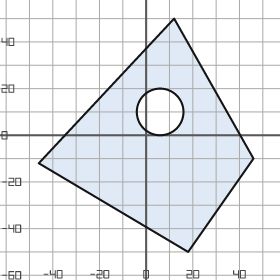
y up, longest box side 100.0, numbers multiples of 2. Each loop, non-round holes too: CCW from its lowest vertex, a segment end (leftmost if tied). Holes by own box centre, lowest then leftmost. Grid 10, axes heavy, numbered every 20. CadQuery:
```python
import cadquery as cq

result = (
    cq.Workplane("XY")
    .moveTo(18.0, -50.0)
    .lineTo(46.0, -10.0)
    .lineTo(12.0, 50.0)
    .lineTo(-46.0, -12.0)
    .close()
    .moveTo(6.0, 10.0)
    .circle(10.0)
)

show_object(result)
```